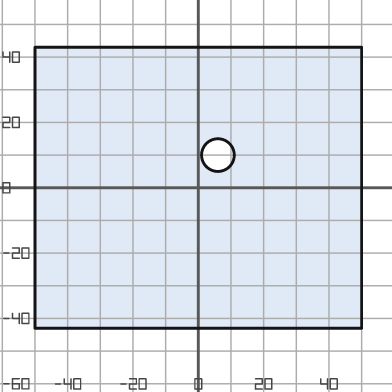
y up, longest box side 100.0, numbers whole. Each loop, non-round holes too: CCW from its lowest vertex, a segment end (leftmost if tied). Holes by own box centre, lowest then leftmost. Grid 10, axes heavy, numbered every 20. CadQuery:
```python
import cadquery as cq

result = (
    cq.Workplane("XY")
    .moveTo(-50.0, -43.0)
    .lineTo(50.0, -43.0)
    .lineTo(50.0, 43.0)
    .lineTo(-50.0, 43.0)
    .close()
    .moveTo(6.0, 10.0)
    .circle(5.0)
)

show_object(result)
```